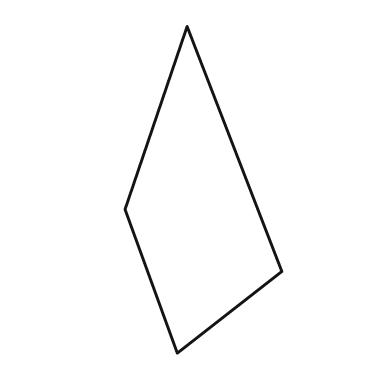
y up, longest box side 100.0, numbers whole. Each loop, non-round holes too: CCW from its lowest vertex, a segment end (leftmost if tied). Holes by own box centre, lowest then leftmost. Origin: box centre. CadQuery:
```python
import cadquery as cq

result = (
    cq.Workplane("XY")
    .moveTo(-8.0, -50.0)
    .lineTo(24.0, -25.0)
    .lineTo(-5.0, 50.0)
    .lineTo(-24.0, -6.0)
    .close()
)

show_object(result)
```